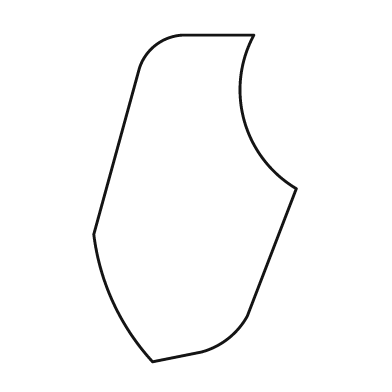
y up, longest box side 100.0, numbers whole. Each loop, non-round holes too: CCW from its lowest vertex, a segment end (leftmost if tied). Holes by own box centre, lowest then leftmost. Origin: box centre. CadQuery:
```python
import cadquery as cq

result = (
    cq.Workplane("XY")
    .moveTo(-13.0, -50.0)
    .lineTo(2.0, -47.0)
    .threePointArc((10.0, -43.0), (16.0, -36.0))
    .lineTo(31.0, 3.0)
    .threePointArc((15.0, 24.0), (18.0, 50.0))
    .lineTo(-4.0, 50.0)
    .threePointArc((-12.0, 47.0), (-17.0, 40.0))
    .lineTo(-31.0, -11.0)
    .threePointArc((-25.0, -32.0), (-13.0, -50.0))
    .close()
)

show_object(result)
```